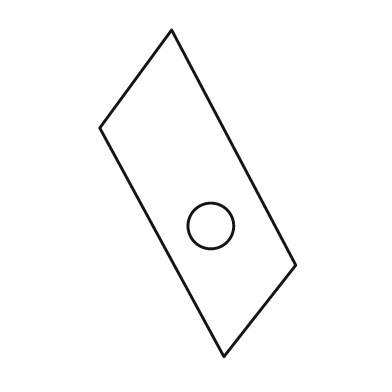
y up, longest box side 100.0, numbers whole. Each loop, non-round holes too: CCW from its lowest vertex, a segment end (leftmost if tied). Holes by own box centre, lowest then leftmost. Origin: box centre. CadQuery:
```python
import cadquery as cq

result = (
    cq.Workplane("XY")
    .moveTo(8.0, -50.0)
    .lineTo(30.0, -22.0)
    .lineTo(-8.0, 50.0)
    .lineTo(-30.0, 20.0)
    .close()
    .moveTo(4.0, -10.0)
    .circle(7.0)
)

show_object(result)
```